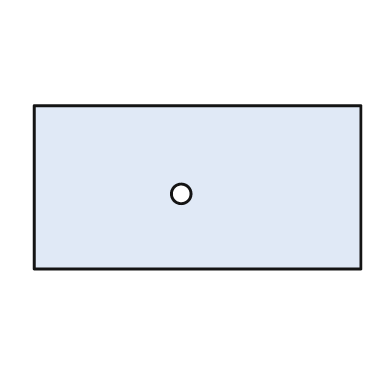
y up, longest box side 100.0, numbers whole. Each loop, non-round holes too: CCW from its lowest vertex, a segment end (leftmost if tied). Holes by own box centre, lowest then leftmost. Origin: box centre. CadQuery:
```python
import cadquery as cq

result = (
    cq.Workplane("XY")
    .moveTo(-50.0, -25.0)
    .lineTo(50.0, -25.0)
    .lineTo(50.0, 25.0)
    .lineTo(-50.0, 25.0)
    .close()
    .moveTo(-5.0, -2.0)
    .circle(3.0)
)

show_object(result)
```